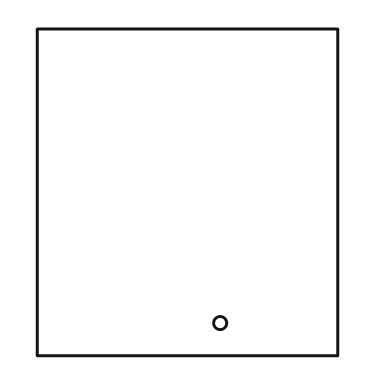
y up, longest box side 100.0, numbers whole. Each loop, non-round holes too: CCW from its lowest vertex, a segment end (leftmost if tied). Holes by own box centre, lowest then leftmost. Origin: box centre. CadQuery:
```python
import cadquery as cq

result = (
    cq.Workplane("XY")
    .moveTo(-46.0, -50.0)
    .lineTo(46.0, -50.0)
    .lineTo(46.0, 50.0)
    .lineTo(-46.0, 50.0)
    .close()
    .moveTo(10.0, -40.0)
    .circle(2.0)
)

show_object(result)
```